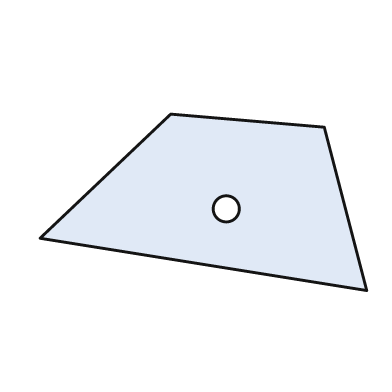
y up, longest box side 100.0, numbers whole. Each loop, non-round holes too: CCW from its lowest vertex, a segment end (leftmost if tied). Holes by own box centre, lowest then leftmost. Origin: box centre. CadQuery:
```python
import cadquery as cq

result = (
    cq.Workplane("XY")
    .moveTo(50.0, -27.0)
    .lineTo(37.0, 23.0)
    .lineTo(-10.0, 27.0)
    .lineTo(-50.0, -11.0)
    .close()
    .moveTo(7.0, -2.0)
    .circle(4.0)
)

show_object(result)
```